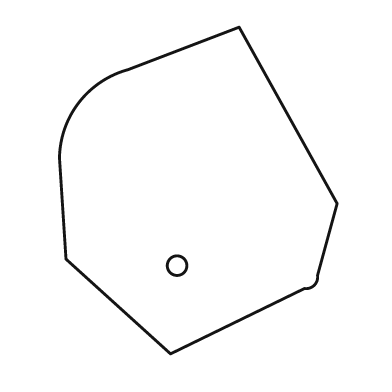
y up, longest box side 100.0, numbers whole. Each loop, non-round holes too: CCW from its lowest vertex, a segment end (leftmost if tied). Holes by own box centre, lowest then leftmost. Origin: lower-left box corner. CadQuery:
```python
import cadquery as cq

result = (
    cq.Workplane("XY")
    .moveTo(34.0, 0.0)
    .lineTo(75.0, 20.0)
    .threePointArc((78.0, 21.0), (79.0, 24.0))
    .lineTo(85.0, 46.0)
    .lineTo(55.0, 100.0)
    .lineTo(21.0, 87.0)
    .threePointArc((6.0, 77.0), (0.0, 60.0))
    .lineTo(2.0, 29.0)
    .close()
    .moveTo(36.0, 27.0)
    .circle(3.0)
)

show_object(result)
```